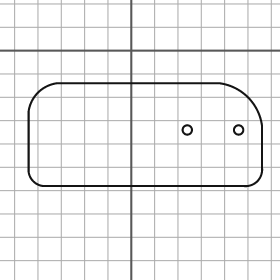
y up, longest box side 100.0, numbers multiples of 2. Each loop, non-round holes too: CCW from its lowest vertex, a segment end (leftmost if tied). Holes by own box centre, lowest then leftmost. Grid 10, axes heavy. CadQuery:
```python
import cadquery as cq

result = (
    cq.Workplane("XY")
    .moveTo(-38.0, -58.0)
    .lineTo(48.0, -58.0)
    .threePointArc((54.0, -56.0), (56.0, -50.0))
    .lineTo(56.0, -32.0)
    .threePointArc((50.0, -20.0), (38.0, -14.0))
    .lineTo(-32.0, -14.0)
    .threePointArc((-40.0, -18.0), (-44.0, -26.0))
    .lineTo(-44.0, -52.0)
    .threePointArc((-42.0, -56.0), (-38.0, -58.0))
    .close()
    .moveTo(24.0, -34.0)
    .circle(2.0)
    .moveTo(46.0, -34.0)
    .circle(2.0)
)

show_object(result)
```